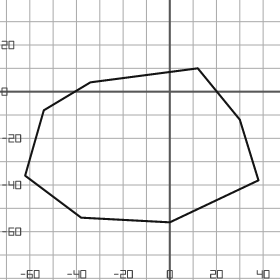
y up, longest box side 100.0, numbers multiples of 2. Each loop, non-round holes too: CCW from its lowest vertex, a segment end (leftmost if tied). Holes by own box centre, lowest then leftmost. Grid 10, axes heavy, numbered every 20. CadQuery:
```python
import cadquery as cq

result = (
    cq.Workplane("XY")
    .moveTo(0.0, -56.0)
    .lineTo(38.0, -38.0)
    .lineTo(30.0, -12.0)
    .lineTo(12.0, 10.0)
    .lineTo(-34.0, 4.0)
    .lineTo(-54.0, -8.0)
    .lineTo(-62.0, -36.0)
    .lineTo(-38.0, -54.0)
    .close()
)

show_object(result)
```